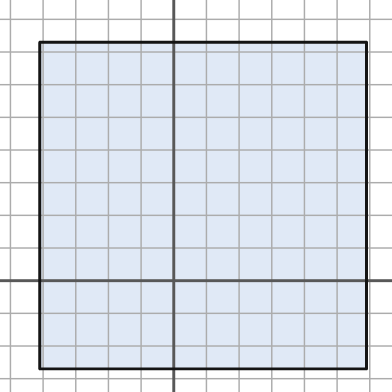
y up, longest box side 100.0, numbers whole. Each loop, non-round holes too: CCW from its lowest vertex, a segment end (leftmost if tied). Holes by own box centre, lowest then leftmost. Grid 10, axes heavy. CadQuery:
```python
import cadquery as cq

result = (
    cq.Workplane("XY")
    .moveTo(-41.0, -27.0)
    .lineTo(59.0, -27.0)
    .lineTo(59.0, 73.0)
    .lineTo(-41.0, 73.0)
    .close()
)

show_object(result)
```